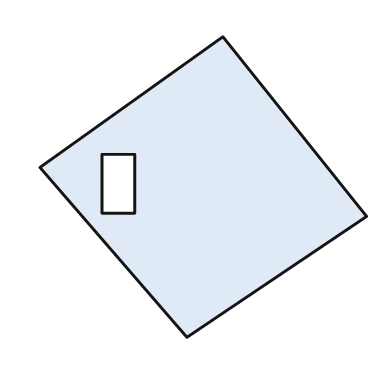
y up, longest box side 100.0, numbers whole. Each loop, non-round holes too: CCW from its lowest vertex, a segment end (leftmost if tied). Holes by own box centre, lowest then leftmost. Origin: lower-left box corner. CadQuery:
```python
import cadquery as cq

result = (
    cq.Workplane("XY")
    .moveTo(45.0, 0.0)
    .lineTo(100.0, 37.0)
    .lineTo(56.0, 92.0)
    .lineTo(0.0, 52.0)
    .close()
    .moveTo(19.0, 38.0)
    .lineTo(29.0, 38.0)
    .lineTo(29.0, 56.0)
    .lineTo(19.0, 56.0)
    .close()
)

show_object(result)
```